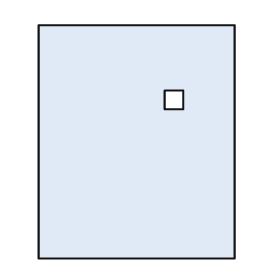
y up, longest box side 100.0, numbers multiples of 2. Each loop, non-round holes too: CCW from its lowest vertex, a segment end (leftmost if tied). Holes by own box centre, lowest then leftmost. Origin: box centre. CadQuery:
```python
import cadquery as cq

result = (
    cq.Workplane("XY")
    .moveTo(-42.0, -50.0)
    .lineTo(42.0, -50.0)
    .lineTo(42.0, 50.0)
    .lineTo(-42.0, 50.0)
    .close()
    .moveTo(12.0, 14.0)
    .lineTo(20.0, 14.0)
    .lineTo(20.0, 22.0)
    .lineTo(12.0, 22.0)
    .close()
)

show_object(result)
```